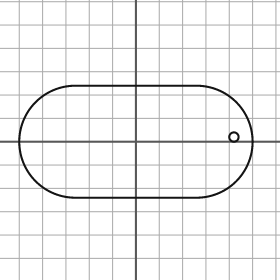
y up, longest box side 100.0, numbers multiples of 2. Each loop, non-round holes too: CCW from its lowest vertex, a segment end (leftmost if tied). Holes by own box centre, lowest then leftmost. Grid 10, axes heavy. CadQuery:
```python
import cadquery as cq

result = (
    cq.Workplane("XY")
    .moveTo(-26.0, -24.0)
    .lineTo(26.0, -24.0)
    .threePointArc((50.0, 0.0), (26.0, 24.0))
    .lineTo(-26.0, 24.0)
    .threePointArc((-50.0, 0.0), (-26.0, -24.0))
    .close()
    .moveTo(42.0, 2.0)
    .circle(2.0)
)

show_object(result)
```